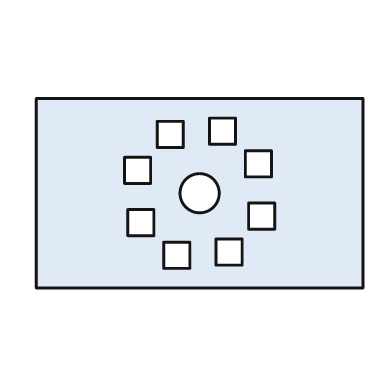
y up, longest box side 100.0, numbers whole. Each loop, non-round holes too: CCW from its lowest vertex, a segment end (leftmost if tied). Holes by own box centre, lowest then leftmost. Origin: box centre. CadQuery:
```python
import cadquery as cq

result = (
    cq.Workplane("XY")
    .moveTo(-50.0, -29.0)
    .lineTo(50.0, -29.0)
    .lineTo(50.0, 29.0)
    .lineTo(-50.0, 29.0)
    .close()
    .moveTo(-11.0, -23.0)
    .lineTo(-3.0, -23.0)
    .lineTo(-3.0, -15.0)
    .lineTo(-11.0, -15.0)
    .close()
    .moveTo(5.0, -22.0)
    .lineTo(13.0, -22.0)
    .lineTo(13.0, -14.0)
    .lineTo(5.0, -14.0)
    .close()
    .moveTo(-22.0, -13.0)
    .lineTo(-14.0, -13.0)
    .lineTo(-14.0, -5.0)
    .lineTo(-22.0, -5.0)
    .close()
    .moveTo(15.0, -11.0)
    .lineTo(23.0, -11.0)
    .lineTo(23.0, -3.0)
    .lineTo(15.0, -3.0)
    .close()
    .moveTo(0.0, 0.0)
    .circle(6.0)
    .moveTo(-23.0, 3.0)
    .lineTo(-15.0, 3.0)
    .lineTo(-15.0, 11.0)
    .lineTo(-23.0, 11.0)
    .close()
    .moveTo(14.0, 5.0)
    .lineTo(22.0, 5.0)
    .lineTo(22.0, 13.0)
    .lineTo(14.0, 13.0)
    .close()
    .moveTo(-13.0, 14.0)
    .lineTo(-5.0, 14.0)
    .lineTo(-5.0, 22.0)
    .lineTo(-13.0, 22.0)
    .close()
    .moveTo(3.0, 15.0)
    .lineTo(11.0, 15.0)
    .lineTo(11.0, 23.0)
    .lineTo(3.0, 23.0)
    .close()
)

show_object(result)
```